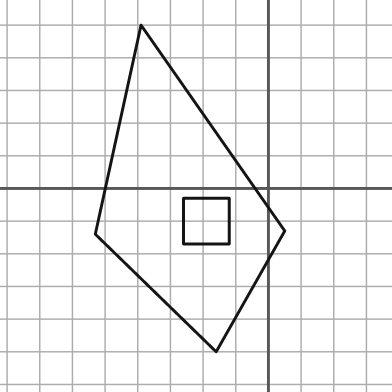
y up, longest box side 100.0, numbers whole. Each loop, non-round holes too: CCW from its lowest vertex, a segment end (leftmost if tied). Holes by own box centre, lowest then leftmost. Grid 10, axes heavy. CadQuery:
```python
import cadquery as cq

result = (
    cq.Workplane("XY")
    .moveTo(-16.0, -50.0)
    .lineTo(5.0, -13.0)
    .lineTo(-39.0, 50.0)
    .lineTo(-53.0, -14.0)
    .close()
    .moveTo(-26.0, -17.0)
    .lineTo(-12.0, -17.0)
    .lineTo(-12.0, -3.0)
    .lineTo(-26.0, -3.0)
    .close()
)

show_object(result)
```